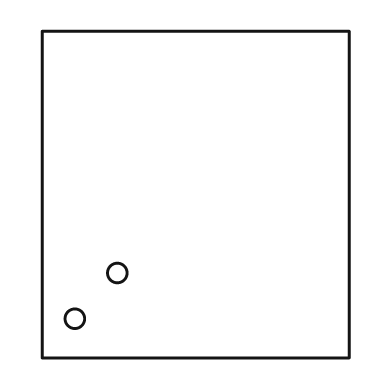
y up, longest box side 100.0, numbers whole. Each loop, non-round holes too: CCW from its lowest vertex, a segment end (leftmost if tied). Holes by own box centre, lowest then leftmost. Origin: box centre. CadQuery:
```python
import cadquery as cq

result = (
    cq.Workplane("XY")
    .moveTo(-47.0, -50.0)
    .lineTo(47.0, -50.0)
    .lineTo(47.0, 50.0)
    .lineTo(-47.0, 50.0)
    .close()
    .moveTo(-37.0, -38.0)
    .circle(3.0)
    .moveTo(-24.0, -24.0)
    .circle(3.0)
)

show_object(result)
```